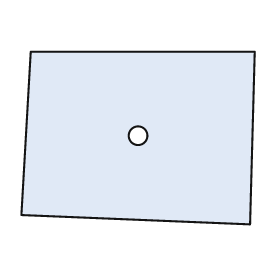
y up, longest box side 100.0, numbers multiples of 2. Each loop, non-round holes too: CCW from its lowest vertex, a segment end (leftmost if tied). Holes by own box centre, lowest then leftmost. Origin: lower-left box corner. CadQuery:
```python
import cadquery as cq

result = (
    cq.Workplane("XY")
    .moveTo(98.0, 0.0)
    .lineTo(100.0, 74.0)
    .lineTo(4.0, 74.0)
    .lineTo(0.0, 4.0)
    .close()
    .moveTo(50.0, 38.0)
    .circle(4.0)
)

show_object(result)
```